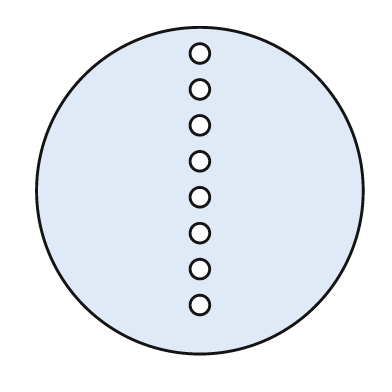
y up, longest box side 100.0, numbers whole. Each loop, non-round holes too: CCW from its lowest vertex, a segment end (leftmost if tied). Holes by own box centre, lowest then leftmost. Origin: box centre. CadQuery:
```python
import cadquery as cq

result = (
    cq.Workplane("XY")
    .moveTo(0.0, 0.0)
    .circle(50.0)
    .moveTo(0.0, -35.0)
    .circle(3.0)
    .moveTo(0.0, -24.0)
    .circle(3.0)
    .moveTo(0.0, -13.0)
    .circle(3.0)
    .moveTo(0.0, -2.0)
    .circle(3.0)
    .moveTo(0.0, 9.0)
    .circle(3.0)
    .moveTo(0.0, 20.0)
    .circle(3.0)
    .moveTo(0.0, 31.0)
    .circle(3.0)
    .moveTo(0.0, 42.0)
    .circle(3.0)
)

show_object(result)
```